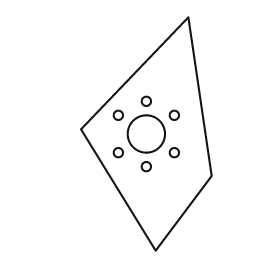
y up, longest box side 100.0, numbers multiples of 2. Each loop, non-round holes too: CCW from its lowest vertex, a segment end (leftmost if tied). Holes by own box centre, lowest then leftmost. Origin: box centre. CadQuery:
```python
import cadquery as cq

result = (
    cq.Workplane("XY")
    .moveTo(4.0, -50.0)
    .lineTo(28.0, -18.0)
    .lineTo(18.0, 50.0)
    .lineTo(-28.0, 2.0)
    .close()
    .moveTo(0.0, -14.0)
    .circle(2.0)
    .moveTo(-12.0, -8.0)
    .circle(2.0)
    .moveTo(12.0, -8.0)
    .circle(2.0)
    .moveTo(0.0, 0.0)
    .circle(8.0)
    .moveTo(-12.0, 8.0)
    .circle(2.0)
    .moveTo(12.0, 8.0)
    .circle(2.0)
    .moveTo(0.0, 14.0)
    .circle(2.0)
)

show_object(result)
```